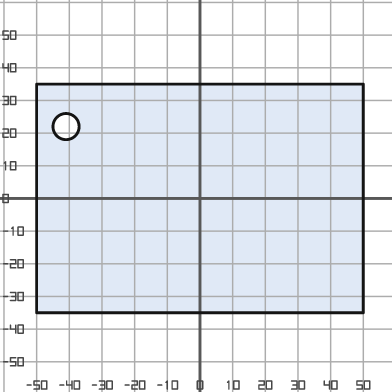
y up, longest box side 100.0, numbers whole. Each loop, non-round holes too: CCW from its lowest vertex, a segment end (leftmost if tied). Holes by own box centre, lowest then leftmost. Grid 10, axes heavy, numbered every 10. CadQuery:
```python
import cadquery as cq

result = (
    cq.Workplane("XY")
    .moveTo(-50.0, -35.0)
    .lineTo(50.0, -35.0)
    .lineTo(50.0, 35.0)
    .lineTo(-50.0, 35.0)
    .close()
    .moveTo(-41.0, 22.0)
    .circle(4.0)
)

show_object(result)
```